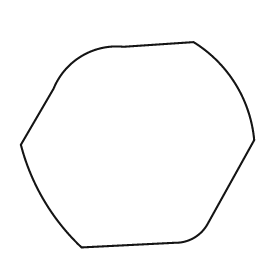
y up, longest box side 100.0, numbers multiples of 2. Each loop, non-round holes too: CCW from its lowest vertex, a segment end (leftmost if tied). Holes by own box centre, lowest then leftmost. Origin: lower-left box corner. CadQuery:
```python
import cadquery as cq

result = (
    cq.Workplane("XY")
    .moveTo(26.0, 0.0)
    .lineTo(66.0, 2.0)
    .threePointArc((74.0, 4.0), (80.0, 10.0))
    .lineTo(100.0, 46.0)
    .threePointArc((92.0, 70.0), (74.0, 88.0))
    .lineTo(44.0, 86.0)
    .threePointArc((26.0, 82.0), (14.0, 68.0))
    .lineTo(0.0, 44.0)
    .threePointArc((10.0, 20.0), (26.0, 0.0))
    .close()
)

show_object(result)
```